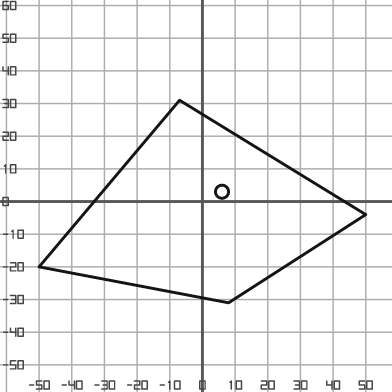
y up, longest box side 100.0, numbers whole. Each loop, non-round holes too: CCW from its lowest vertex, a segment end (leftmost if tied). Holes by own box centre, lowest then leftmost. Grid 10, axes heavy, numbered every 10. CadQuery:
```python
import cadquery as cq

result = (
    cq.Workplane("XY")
    .moveTo(8.0, -31.0)
    .lineTo(50.0, -4.0)
    .lineTo(-7.0, 31.0)
    .lineTo(-50.0, -20.0)
    .close()
    .moveTo(6.0, 3.0)
    .circle(2.0)
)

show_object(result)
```